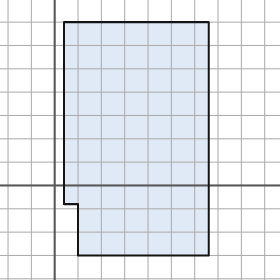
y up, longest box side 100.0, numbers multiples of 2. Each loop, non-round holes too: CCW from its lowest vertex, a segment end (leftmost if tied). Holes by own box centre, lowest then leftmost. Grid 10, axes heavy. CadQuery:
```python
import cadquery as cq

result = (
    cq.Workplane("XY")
    .moveTo(10.0, -30.0)
    .lineTo(66.0, -30.0)
    .lineTo(66.0, 70.0)
    .lineTo(4.0, 70.0)
    .lineTo(4.0, -8.0)
    .lineTo(10.0, -8.0)
    .close()
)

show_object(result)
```